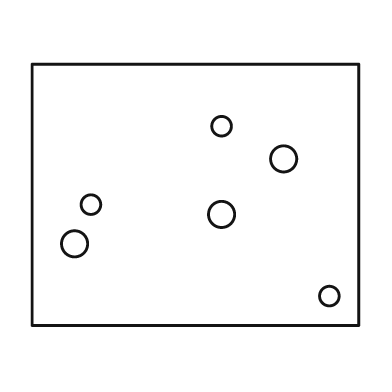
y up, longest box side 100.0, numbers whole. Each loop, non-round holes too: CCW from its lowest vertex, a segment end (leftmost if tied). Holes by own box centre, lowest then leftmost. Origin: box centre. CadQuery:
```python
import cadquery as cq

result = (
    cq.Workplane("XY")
    .moveTo(-50.0, -40.0)
    .lineTo(50.0, -40.0)
    .lineTo(50.0, 40.0)
    .lineTo(-50.0, 40.0)
    .close()
    .moveTo(41.0, -31.0)
    .circle(3.0)
    .moveTo(-37.0, -15.0)
    .circle(4.0)
    .moveTo(8.0, -6.0)
    .circle(4.0)
    .moveTo(-32.0, -3.0)
    .circle(3.0)
    .moveTo(27.0, 11.0)
    .circle(4.0)
    .moveTo(8.0, 21.0)
    .circle(3.0)
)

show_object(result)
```